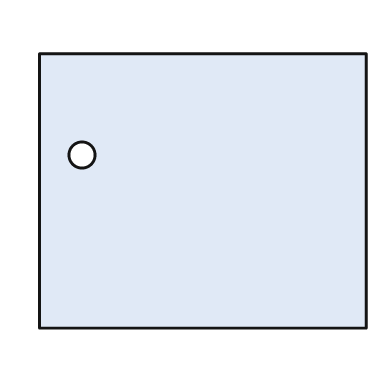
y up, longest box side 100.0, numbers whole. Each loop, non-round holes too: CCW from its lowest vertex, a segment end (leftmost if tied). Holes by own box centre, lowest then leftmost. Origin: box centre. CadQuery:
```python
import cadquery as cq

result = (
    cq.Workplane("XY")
    .moveTo(-50.0, -42.0)
    .lineTo(50.0, -42.0)
    .lineTo(50.0, 42.0)
    .lineTo(-50.0, 42.0)
    .close()
    .moveTo(-37.0, 11.0)
    .circle(4.0)
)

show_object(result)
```